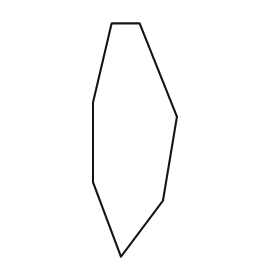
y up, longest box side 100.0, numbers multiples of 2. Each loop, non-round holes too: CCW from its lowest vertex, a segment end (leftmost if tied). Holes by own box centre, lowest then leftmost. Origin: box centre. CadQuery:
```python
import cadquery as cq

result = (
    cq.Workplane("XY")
    .moveTo(-6.0, -50.0)
    .lineTo(12.0, -26.0)
    .lineTo(18.0, 10.0)
    .lineTo(2.0, 50.0)
    .lineTo(-10.0, 50.0)
    .lineTo(-18.0, 16.0)
    .lineTo(-18.0, -18.0)
    .close()
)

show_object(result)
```